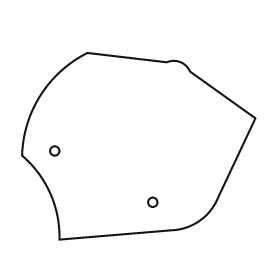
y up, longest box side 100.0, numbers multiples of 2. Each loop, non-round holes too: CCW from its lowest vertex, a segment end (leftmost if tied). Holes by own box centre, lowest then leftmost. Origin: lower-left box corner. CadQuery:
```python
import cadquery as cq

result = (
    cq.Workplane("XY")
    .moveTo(16.0, 0.0)
    .lineTo(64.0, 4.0)
    .threePointArc((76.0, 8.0), (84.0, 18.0))
    .lineTo(100.0, 52.0)
    .lineTo(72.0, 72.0)
    .threePointArc((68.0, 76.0), (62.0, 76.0))
    .lineTo(28.0, 80.0)
    .threePointArc((8.0, 62.0), (0.0, 36.0))
    .threePointArc((12.0, 20.0), (16.0, 0.0))
    .close()
    .moveTo(56.0, 16.0)
    .circle(2.0)
    .moveTo(14.0, 38.0)
    .circle(2.0)
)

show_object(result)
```